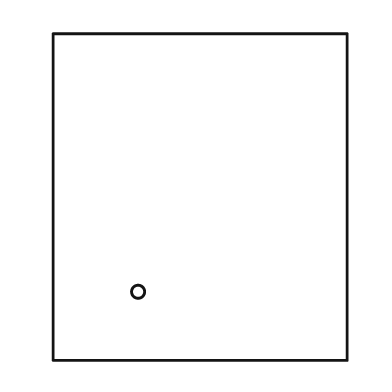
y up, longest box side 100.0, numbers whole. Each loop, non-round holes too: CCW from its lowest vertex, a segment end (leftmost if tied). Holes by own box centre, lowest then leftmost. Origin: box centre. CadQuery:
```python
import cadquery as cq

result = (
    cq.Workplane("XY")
    .moveTo(-45.0, -50.0)
    .lineTo(45.0, -50.0)
    .lineTo(45.0, 50.0)
    .lineTo(-45.0, 50.0)
    .close()
    .moveTo(-19.0, -29.0)
    .circle(2.0)
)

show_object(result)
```